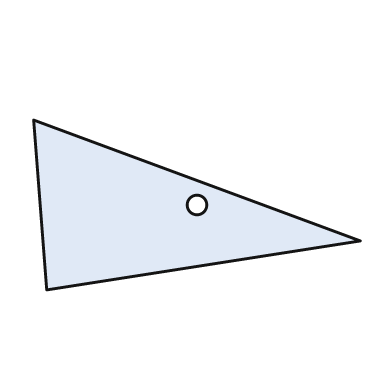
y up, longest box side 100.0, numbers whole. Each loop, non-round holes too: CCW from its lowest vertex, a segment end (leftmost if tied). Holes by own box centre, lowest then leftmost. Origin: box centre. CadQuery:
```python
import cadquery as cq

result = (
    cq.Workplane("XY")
    .moveTo(-46.0, -26.0)
    .lineTo(50.0, -11.0)
    .lineTo(-50.0, 26.0)
    .close()
    .moveTo(0.0, 0.0)
    .circle(3.0)
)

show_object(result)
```